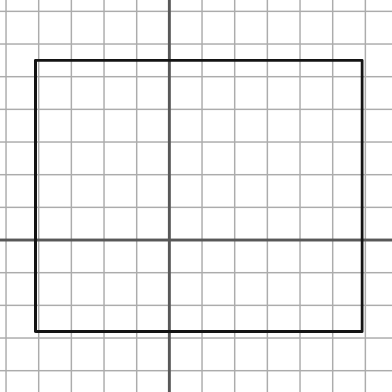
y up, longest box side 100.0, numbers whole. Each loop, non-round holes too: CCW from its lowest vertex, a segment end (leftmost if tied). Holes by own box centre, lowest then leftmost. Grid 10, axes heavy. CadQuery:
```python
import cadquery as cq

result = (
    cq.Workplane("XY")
    .moveTo(-41.0, -28.0)
    .lineTo(59.0, -28.0)
    .lineTo(59.0, 55.0)
    .lineTo(-41.0, 55.0)
    .close()
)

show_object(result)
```